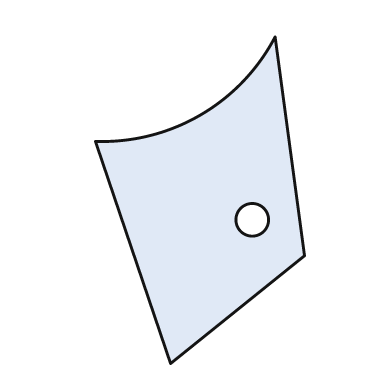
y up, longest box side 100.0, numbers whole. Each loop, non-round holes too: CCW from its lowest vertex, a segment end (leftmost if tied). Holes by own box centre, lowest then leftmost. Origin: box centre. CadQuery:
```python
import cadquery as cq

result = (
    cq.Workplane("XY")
    .moveTo(-9.0, -50.0)
    .lineTo(32.0, -17.0)
    .lineTo(23.0, 50.0)
    .threePointArc((0.0, 26.0), (-32.0, 18.0))
    .close()
    .moveTo(16.0, -6.0)
    .circle(5.0)
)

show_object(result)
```